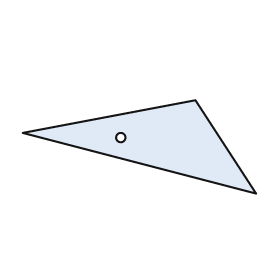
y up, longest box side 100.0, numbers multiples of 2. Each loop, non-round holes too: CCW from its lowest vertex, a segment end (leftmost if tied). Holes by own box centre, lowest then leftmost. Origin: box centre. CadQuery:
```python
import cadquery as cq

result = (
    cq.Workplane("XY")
    .moveTo(50.0, -20.0)
    .lineTo(24.0, 20.0)
    .lineTo(-50.0, 6.0)
    .close()
    .moveTo(-8.0, 4.0)
    .circle(2.0)
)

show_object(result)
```